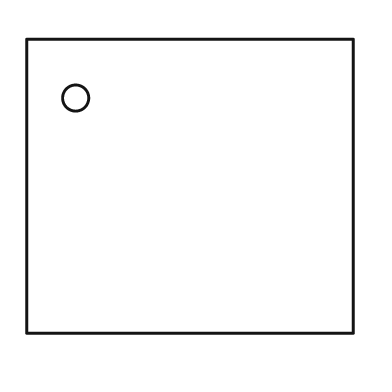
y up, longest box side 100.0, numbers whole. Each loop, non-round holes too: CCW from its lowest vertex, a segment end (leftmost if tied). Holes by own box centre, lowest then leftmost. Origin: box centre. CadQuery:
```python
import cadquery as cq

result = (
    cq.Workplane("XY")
    .moveTo(-50.0, -45.0)
    .lineTo(50.0, -45.0)
    .lineTo(50.0, 45.0)
    .lineTo(-50.0, 45.0)
    .close()
    .moveTo(-35.0, 27.0)
    .circle(4.0)
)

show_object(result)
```